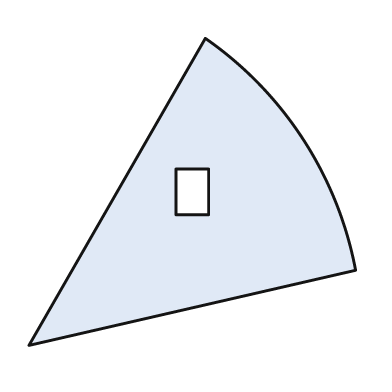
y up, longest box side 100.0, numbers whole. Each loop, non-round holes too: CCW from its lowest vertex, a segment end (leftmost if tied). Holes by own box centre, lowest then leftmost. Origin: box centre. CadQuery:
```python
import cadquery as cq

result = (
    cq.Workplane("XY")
    .moveTo(-50.0, -47.0)
    .lineTo(50.0, -24.0)
    .threePointArc((34.0, 16.0), (4.0, 47.0))
    .close()
    .moveTo(-5.0, -7.0)
    .lineTo(5.0, -7.0)
    .lineTo(5.0, 7.0)
    .lineTo(-5.0, 7.0)
    .close()
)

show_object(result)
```